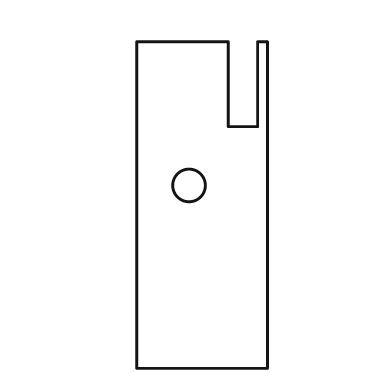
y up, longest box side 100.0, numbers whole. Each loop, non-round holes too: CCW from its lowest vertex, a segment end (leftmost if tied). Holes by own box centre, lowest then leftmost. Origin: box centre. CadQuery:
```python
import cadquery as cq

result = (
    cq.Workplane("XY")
    .moveTo(-20.0, -50.0)
    .lineTo(20.0, -50.0)
    .lineTo(20.0, 50.0)
    .lineTo(17.0, 50.0)
    .lineTo(17.0, 24.0)
    .lineTo(8.0, 24.0)
    .lineTo(8.0, 50.0)
    .lineTo(-20.0, 50.0)
    .close()
    .moveTo(-4.0, 6.0)
    .circle(5.0)
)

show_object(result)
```